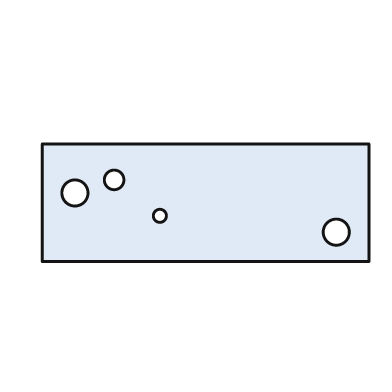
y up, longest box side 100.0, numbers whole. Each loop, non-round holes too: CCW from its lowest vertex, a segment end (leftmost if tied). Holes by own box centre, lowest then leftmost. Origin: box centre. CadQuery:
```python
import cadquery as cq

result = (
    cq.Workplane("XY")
    .moveTo(-50.0, -18.0)
    .lineTo(50.0, -18.0)
    .lineTo(50.0, 18.0)
    .lineTo(-50.0, 18.0)
    .close()
    .moveTo(40.0, -9.0)
    .circle(4.0)
    .moveTo(-14.0, -4.0)
    .circle(2.0)
    .moveTo(-40.0, 3.0)
    .circle(4.0)
    .moveTo(-28.0, 7.0)
    .circle(3.0)
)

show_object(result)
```